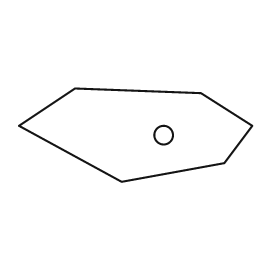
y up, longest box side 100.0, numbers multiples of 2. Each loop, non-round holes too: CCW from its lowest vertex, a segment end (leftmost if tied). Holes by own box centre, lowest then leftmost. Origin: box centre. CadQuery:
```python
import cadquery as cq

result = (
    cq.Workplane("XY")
    .moveTo(-6.0, -20.0)
    .lineTo(38.0, -12.0)
    .lineTo(50.0, 4.0)
    .lineTo(28.0, 18.0)
    .lineTo(-26.0, 20.0)
    .lineTo(-50.0, 4.0)
    .close()
    .moveTo(12.0, 0.0)
    .circle(4.0)
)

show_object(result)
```